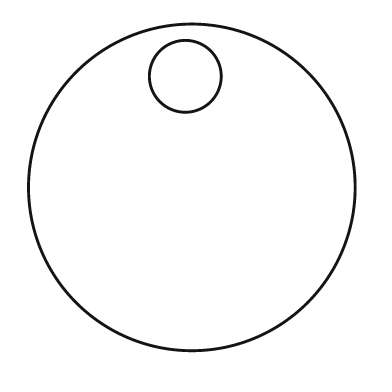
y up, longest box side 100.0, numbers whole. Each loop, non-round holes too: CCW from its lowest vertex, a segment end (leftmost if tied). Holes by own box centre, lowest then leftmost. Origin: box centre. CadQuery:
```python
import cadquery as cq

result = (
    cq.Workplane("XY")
    .moveTo(0.0, 0.0)
    .circle(50.0)
    .moveTo(-2.0, 34.0)
    .circle(11.0)
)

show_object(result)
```